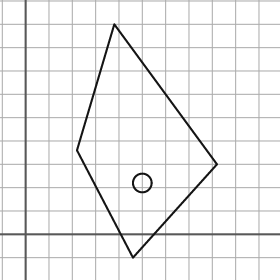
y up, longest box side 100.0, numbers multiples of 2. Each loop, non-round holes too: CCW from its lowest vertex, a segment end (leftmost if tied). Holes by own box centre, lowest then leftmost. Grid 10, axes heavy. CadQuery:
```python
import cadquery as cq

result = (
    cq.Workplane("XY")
    .moveTo(46.0, -10.0)
    .lineTo(82.0, 30.0)
    .lineTo(38.0, 90.0)
    .lineTo(22.0, 36.0)
    .close()
    .moveTo(50.0, 22.0)
    .circle(4.0)
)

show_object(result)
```